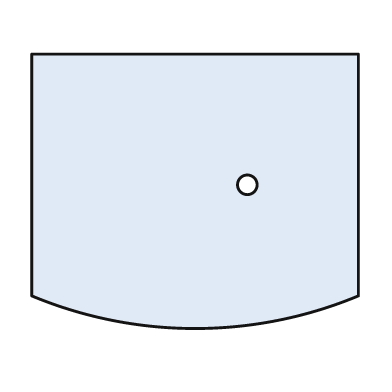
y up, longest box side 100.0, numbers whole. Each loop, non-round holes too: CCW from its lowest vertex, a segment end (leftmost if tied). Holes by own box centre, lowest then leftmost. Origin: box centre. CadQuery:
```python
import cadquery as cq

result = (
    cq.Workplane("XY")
    .moveTo(-50.0, -32.0)
    .threePointArc((0.0, -42.0), (50.0, -32.0))
    .lineTo(50.0, 42.0)
    .lineTo(-50.0, 42.0)
    .close()
    .moveTo(16.0, 2.0)
    .circle(3.0)
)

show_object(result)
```